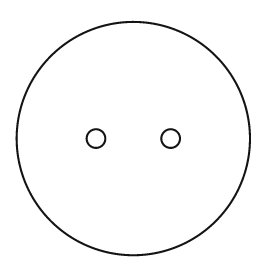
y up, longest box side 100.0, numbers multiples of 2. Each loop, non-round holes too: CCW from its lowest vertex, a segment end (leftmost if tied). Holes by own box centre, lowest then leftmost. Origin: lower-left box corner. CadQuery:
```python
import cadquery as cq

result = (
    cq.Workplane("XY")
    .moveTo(50.0, 50.0)
    .circle(50.0)
    .moveTo(34.0, 50.0)
    .circle(4.0)
    .moveTo(66.0, 50.0)
    .circle(4.0)
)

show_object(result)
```